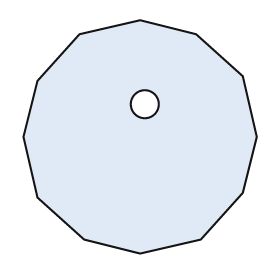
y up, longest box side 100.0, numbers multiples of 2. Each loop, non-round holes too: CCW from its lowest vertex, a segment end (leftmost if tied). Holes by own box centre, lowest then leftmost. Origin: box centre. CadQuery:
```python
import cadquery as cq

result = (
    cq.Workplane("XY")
    .moveTo(0.0, -50.0)
    .lineTo(26.0, -44.0)
    .lineTo(44.0, -24.0)
    .lineTo(50.0, 0.0)
    .lineTo(44.0, 26.0)
    .lineTo(24.0, 44.0)
    .lineTo(0.0, 50.0)
    .lineTo(-26.0, 44.0)
    .lineTo(-44.0, 24.0)
    .lineTo(-50.0, 0.0)
    .lineTo(-44.0, -26.0)
    .lineTo(-24.0, -44.0)
    .close()
    .moveTo(2.0, 14.0)
    .circle(6.0)
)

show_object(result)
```